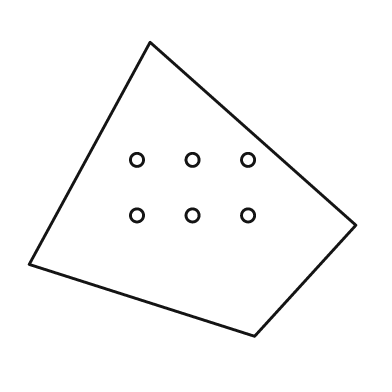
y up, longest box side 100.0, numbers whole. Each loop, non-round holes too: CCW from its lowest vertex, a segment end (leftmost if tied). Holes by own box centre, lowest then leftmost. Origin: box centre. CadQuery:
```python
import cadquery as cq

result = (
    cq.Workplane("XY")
    .moveTo(19.0, -45.0)
    .lineTo(50.0, -11.0)
    .lineTo(-13.0, 45.0)
    .lineTo(-50.0, -23.0)
    .close()
    .moveTo(-17.0, -8.0)
    .circle(2.0)
    .moveTo(0.0, -8.0)
    .circle(2.0)
    .moveTo(17.0, -8.0)
    .circle(2.0)
    .moveTo(-17.0, 9.0)
    .circle(2.0)
    .moveTo(0.0, 9.0)
    .circle(2.0)
    .moveTo(17.0, 9.0)
    .circle(2.0)
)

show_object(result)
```